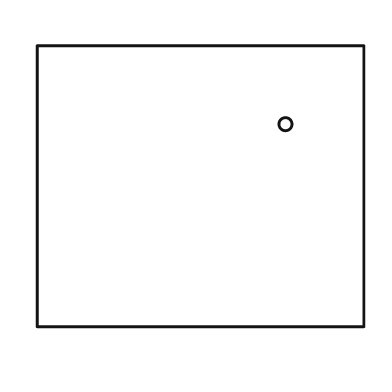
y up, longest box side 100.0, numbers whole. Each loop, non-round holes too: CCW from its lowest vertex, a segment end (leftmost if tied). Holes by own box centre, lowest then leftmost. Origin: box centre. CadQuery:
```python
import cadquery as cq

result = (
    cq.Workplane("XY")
    .moveTo(-50.0, -43.0)
    .lineTo(50.0, -43.0)
    .lineTo(50.0, 43.0)
    .lineTo(-50.0, 43.0)
    .close()
    .moveTo(26.0, 19.0)
    .circle(2.0)
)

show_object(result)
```